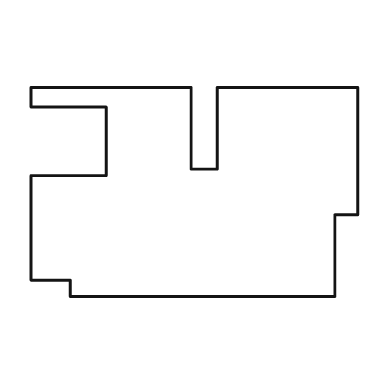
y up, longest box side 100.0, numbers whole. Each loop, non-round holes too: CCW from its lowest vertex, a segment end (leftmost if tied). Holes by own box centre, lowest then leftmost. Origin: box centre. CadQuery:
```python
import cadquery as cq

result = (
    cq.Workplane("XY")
    .moveTo(-38.0, -32.0)
    .lineTo(43.0, -32.0)
    .lineTo(43.0, -7.0)
    .lineTo(50.0, -7.0)
    .lineTo(50.0, 32.0)
    .lineTo(7.0, 32.0)
    .lineTo(7.0, 7.0)
    .lineTo(-1.0, 7.0)
    .lineTo(-1.0, 32.0)
    .lineTo(-50.0, 32.0)
    .lineTo(-50.0, 26.0)
    .lineTo(-27.0, 26.0)
    .lineTo(-27.0, 5.0)
    .lineTo(-50.0, 5.0)
    .lineTo(-50.0, -27.0)
    .lineTo(-38.0, -27.0)
    .close()
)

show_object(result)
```